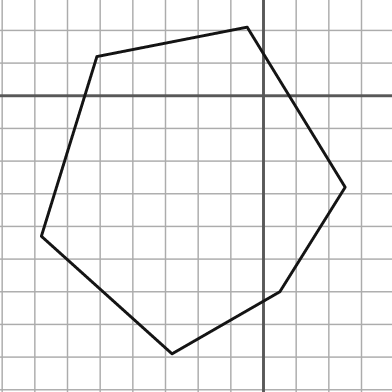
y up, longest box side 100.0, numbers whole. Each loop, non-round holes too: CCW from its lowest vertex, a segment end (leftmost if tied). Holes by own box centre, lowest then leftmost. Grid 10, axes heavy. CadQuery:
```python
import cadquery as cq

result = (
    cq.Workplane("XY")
    .moveTo(-28.0, -79.0)
    .lineTo(5.0, -60.0)
    .lineTo(25.0, -28.0)
    .lineTo(-5.0, 21.0)
    .lineTo(-51.0, 12.0)
    .lineTo(-68.0, -43.0)
    .close()
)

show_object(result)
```